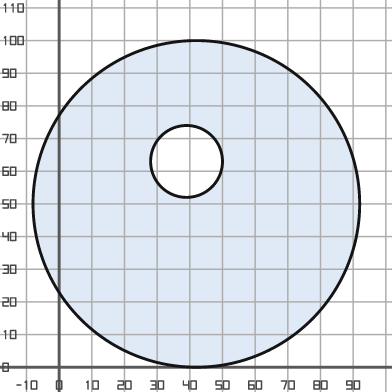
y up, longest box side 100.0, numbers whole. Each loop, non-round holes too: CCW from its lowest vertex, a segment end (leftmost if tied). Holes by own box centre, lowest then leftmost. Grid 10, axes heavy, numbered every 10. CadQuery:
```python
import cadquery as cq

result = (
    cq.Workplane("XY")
    .moveTo(42.0, 50.0)
    .circle(50.0)
    .moveTo(39.0, 63.0)
    .circle(11.0)
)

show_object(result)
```